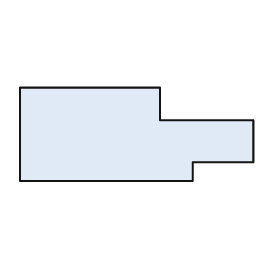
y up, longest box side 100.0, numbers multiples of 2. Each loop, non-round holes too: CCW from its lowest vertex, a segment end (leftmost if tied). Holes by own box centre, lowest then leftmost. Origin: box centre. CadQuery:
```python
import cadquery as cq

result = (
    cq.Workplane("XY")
    .moveTo(-50.0, -20.0)
    .lineTo(24.0, -20.0)
    .lineTo(24.0, -12.0)
    .lineTo(50.0, -12.0)
    .lineTo(50.0, 6.0)
    .lineTo(10.0, 6.0)
    .lineTo(10.0, 20.0)
    .lineTo(-50.0, 20.0)
    .close()
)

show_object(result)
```